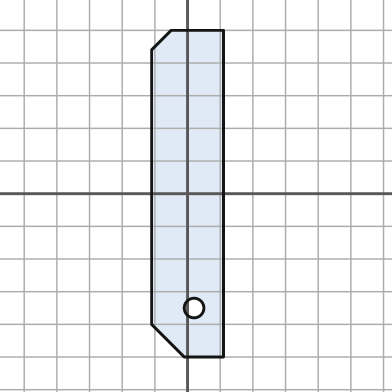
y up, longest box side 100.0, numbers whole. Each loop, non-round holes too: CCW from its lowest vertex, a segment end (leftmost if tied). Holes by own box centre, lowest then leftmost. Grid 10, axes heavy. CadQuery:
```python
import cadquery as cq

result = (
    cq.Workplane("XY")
    .moveTo(-1.0, -50.0)
    .lineTo(11.0, -50.0)
    .lineTo(11.0, 50.0)
    .lineTo(-5.0, 50.0)
    .lineTo(-11.0, 44.0)
    .lineTo(-11.0, -40.0)
    .close()
    .moveTo(2.0, -35.0)
    .circle(3.0)
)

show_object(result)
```